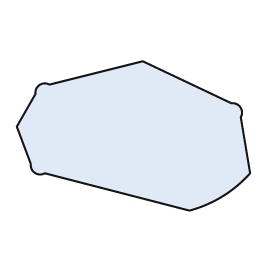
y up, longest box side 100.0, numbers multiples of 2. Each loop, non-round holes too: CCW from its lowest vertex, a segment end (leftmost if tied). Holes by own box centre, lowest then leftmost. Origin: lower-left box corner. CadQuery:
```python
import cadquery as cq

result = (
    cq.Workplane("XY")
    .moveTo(74.0, 0.0)
    .threePointArc((88.0, 6.0), (100.0, 16.0))
    .lineTo(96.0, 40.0)
    .threePointArc((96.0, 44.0), (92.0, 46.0))
    .lineTo(54.0, 64.0)
    .lineTo(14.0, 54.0)
    .threePointArc((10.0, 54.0), (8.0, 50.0))
    .lineTo(0.0, 36.0)
    .lineTo(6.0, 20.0)
    .threePointArc((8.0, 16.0), (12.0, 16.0))
    .close()
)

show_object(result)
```